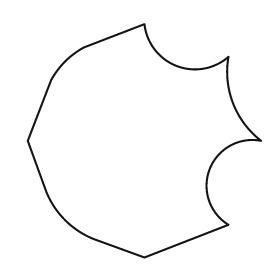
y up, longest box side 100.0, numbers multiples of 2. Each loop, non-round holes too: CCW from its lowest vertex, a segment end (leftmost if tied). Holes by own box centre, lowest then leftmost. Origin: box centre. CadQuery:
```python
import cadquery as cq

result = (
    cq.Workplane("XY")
    .moveTo(0.0, -50.0)
    .lineTo(36.0, -36.0)
    .threePointArc((28.0, -12.0), (50.0, 0.0))
    .threePointArc((38.0, 16.0), (36.0, 36.0))
    .threePointArc((14.0, 32.0), (0.0, 50.0))
    .lineTo(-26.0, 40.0)
    .threePointArc((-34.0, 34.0), (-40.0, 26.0))
    .lineTo(-50.0, 0.0)
    .lineTo(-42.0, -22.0)
    .threePointArc((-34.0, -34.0), (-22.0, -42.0))
    .close()
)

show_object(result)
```